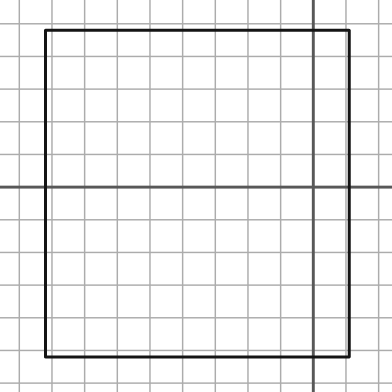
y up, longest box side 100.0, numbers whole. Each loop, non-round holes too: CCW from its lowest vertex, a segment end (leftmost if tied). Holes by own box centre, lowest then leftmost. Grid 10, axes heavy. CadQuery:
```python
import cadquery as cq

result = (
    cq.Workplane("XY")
    .moveTo(-82.0, -52.0)
    .lineTo(11.0, -52.0)
    .lineTo(11.0, 48.0)
    .lineTo(-82.0, 48.0)
    .close()
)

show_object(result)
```